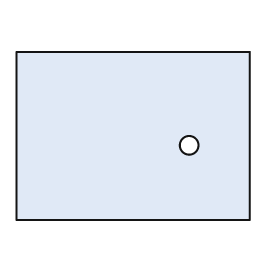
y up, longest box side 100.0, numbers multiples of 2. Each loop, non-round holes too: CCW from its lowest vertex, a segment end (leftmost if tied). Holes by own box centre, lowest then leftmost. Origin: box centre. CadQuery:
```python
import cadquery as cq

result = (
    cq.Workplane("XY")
    .moveTo(-50.0, -36.0)
    .lineTo(50.0, -36.0)
    .lineTo(50.0, 36.0)
    .lineTo(-50.0, 36.0)
    .close()
    .moveTo(24.0, -4.0)
    .circle(4.0)
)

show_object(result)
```